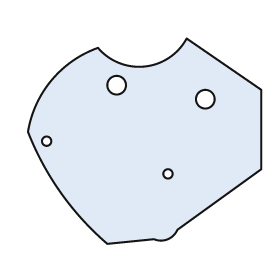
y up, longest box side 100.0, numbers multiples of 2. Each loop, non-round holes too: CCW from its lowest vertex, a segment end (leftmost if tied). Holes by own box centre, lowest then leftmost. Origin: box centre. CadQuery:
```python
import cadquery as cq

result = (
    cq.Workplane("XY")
    .moveTo(-16.0, -44.0)
    .lineTo(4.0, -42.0)
    .threePointArc((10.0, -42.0), (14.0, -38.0))
    .lineTo(50.0, -12.0)
    .lineTo(50.0, 22.0)
    .lineTo(18.0, 44.0)
    .threePointArc((0.0, 32.0), (-20.0, 40.0))
    .threePointArc((-40.0, 26.0), (-50.0, 4.0))
    .threePointArc((-36.0, -22.0), (-16.0, -44.0))
    .close()
    .moveTo(10.0, -14.0)
    .circle(2.0)
    .moveTo(-42.0, 0.0)
    .circle(2.0)
    .moveTo(26.0, 18.0)
    .circle(4.0)
    .moveTo(-12.0, 24.0)
    .circle(4.0)
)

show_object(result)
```